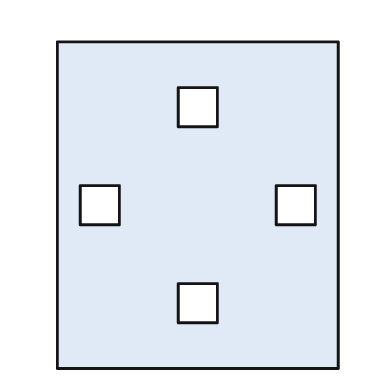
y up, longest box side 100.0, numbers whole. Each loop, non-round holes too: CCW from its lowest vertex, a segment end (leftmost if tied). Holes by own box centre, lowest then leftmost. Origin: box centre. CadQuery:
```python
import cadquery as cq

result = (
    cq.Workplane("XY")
    .moveTo(-43.0, -50.0)
    .lineTo(43.0, -50.0)
    .lineTo(43.0, 50.0)
    .lineTo(-43.0, 50.0)
    .close()
    .moveTo(-6.0, -36.0)
    .lineTo(6.0, -36.0)
    .lineTo(6.0, -24.0)
    .lineTo(-6.0, -24.0)
    .close()
    .moveTo(-36.0, -6.0)
    .lineTo(-24.0, -6.0)
    .lineTo(-24.0, 6.0)
    .lineTo(-36.0, 6.0)
    .close()
    .moveTo(24.0, -6.0)
    .lineTo(36.0, -6.0)
    .lineTo(36.0, 6.0)
    .lineTo(24.0, 6.0)
    .close()
    .moveTo(-6.0, 24.0)
    .lineTo(6.0, 24.0)
    .lineTo(6.0, 36.0)
    .lineTo(-6.0, 36.0)
    .close()
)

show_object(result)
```